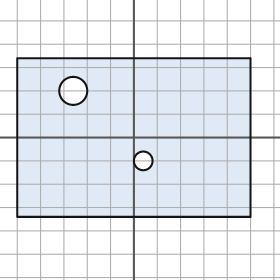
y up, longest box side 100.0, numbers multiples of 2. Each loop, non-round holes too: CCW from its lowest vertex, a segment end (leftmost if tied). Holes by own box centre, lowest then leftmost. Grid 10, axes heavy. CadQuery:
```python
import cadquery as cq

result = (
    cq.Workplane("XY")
    .moveTo(-50.0, -34.0)
    .lineTo(50.0, -34.0)
    .lineTo(50.0, 34.0)
    .lineTo(-50.0, 34.0)
    .close()
    .moveTo(4.0, -10.0)
    .circle(4.0)
    .moveTo(-26.0, 20.0)
    .circle(6.0)
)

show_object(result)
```